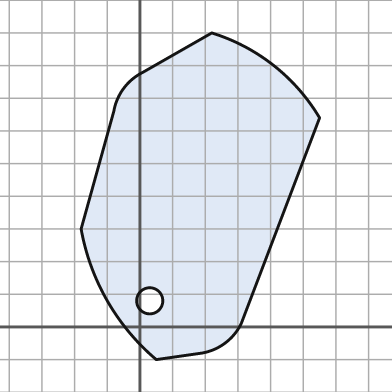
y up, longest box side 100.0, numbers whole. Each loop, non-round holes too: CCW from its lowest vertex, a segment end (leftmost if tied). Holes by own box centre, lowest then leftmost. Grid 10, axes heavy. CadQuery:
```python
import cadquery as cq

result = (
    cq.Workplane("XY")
    .moveTo(5.0, -10.0)
    .lineTo(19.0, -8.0)
    .threePointArc((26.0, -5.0), (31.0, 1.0))
    .lineTo(55.0, 64.0)
    .threePointArc((41.0, 80.0), (22.0, 90.0))
    .lineTo(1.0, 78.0)
    .threePointArc((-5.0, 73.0), (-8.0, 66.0))
    .lineTo(-18.0, 30.0)
    .threePointArc((-10.0, 8.0), (5.0, -10.0))
    .close()
    .moveTo(3.0, 8.0)
    .circle(4.0)
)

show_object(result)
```